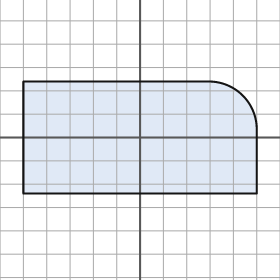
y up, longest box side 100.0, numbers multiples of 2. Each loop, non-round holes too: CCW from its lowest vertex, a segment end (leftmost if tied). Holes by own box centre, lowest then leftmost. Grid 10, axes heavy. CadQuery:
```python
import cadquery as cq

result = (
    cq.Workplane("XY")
    .moveTo(-50.0, -24.0)
    .lineTo(50.0, -24.0)
    .lineTo(50.0, 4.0)
    .threePointArc((44.0, 18.0), (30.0, 24.0))
    .lineTo(-50.0, 24.0)
    .close()
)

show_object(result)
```